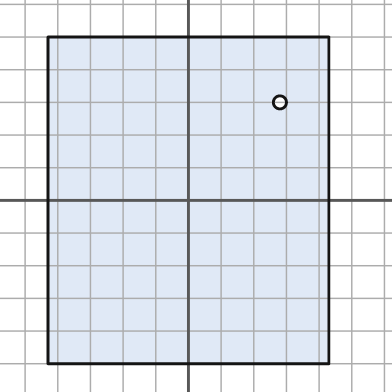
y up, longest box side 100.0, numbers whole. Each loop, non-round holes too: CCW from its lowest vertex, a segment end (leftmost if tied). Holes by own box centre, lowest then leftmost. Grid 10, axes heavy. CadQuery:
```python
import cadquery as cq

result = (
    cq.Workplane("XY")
    .moveTo(-43.0, -50.0)
    .lineTo(43.0, -50.0)
    .lineTo(43.0, 50.0)
    .lineTo(-43.0, 50.0)
    .close()
    .moveTo(28.0, 30.0)
    .circle(2.0)
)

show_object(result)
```